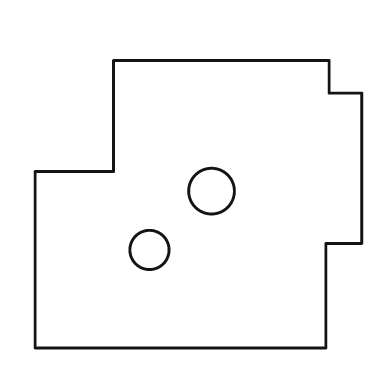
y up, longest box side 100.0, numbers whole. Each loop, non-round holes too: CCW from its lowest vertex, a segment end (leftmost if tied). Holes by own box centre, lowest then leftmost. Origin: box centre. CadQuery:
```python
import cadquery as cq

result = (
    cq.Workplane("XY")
    .moveTo(-50.0, -44.0)
    .lineTo(39.0, -44.0)
    .lineTo(39.0, -12.0)
    .lineTo(50.0, -12.0)
    .lineTo(50.0, 34.0)
    .lineTo(40.0, 34.0)
    .lineTo(40.0, 44.0)
    .lineTo(-26.0, 44.0)
    .lineTo(-26.0, 10.0)
    .lineTo(-50.0, 10.0)
    .close()
    .moveTo(-15.0, -14.0)
    .circle(6.0)
    .moveTo(4.0, 4.0)
    .circle(7.0)
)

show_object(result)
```